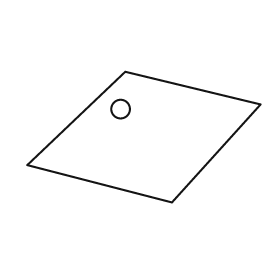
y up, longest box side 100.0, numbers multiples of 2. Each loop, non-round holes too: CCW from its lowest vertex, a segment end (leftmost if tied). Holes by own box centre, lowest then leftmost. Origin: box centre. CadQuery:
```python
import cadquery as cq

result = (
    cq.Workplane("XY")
    .moveTo(12.0, -28.0)
    .lineTo(50.0, 14.0)
    .lineTo(-8.0, 28.0)
    .lineTo(-50.0, -12.0)
    .close()
    .moveTo(-10.0, 12.0)
    .circle(4.0)
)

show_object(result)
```